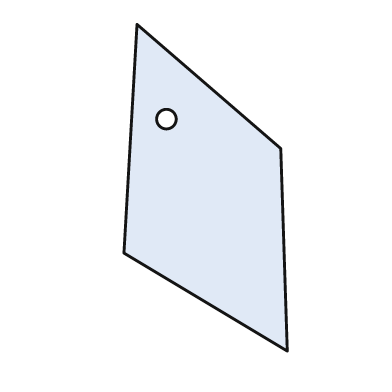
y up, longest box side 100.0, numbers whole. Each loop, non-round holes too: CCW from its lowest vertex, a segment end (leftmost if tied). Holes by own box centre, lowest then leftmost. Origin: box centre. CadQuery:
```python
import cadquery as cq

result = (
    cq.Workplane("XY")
    .moveTo(25.0, -50.0)
    .lineTo(23.0, 12.0)
    .lineTo(-21.0, 50.0)
    .lineTo(-25.0, -20.0)
    .close()
    .moveTo(-12.0, 21.0)
    .circle(3.0)
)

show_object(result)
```